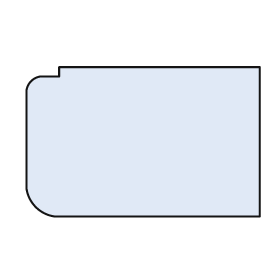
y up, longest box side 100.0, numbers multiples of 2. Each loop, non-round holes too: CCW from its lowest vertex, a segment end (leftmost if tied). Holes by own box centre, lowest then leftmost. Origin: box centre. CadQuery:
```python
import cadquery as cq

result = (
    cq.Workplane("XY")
    .moveTo(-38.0, -32.0)
    .lineTo(50.0, -32.0)
    .lineTo(50.0, 32.0)
    .lineTo(-36.0, 32.0)
    .lineTo(-36.0, 28.0)
    .lineTo(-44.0, 28.0)
    .threePointArc((-48.0, 26.0), (-50.0, 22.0))
    .lineTo(-50.0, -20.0)
    .threePointArc((-46.0, -28.0), (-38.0, -32.0))
    .close()
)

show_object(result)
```